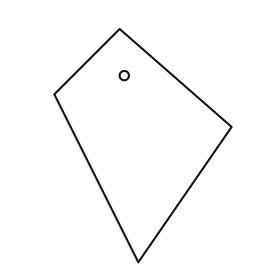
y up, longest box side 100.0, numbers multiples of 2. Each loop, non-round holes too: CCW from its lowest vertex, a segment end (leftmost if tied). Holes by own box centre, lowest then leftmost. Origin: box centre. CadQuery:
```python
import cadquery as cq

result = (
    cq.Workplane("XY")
    .moveTo(-2.0, -50.0)
    .lineTo(38.0, 8.0)
    .lineTo(-10.0, 50.0)
    .lineTo(-38.0, 22.0)
    .close()
    .moveTo(-8.0, 30.0)
    .circle(2.0)
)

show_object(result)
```